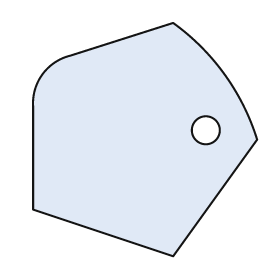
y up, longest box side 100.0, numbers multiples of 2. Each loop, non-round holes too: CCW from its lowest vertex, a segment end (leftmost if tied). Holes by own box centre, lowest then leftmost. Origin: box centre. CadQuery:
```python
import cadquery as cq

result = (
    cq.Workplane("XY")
    .moveTo(12.0, -50.0)
    .lineTo(48.0, 0.0)
    .threePointArc((34.0, 28.0), (12.0, 50.0))
    .lineTo(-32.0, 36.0)
    .threePointArc((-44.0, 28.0), (-48.0, 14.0))
    .lineTo(-48.0, -30.0)
    .close()
    .moveTo(26.0, 4.0)
    .circle(6.0)
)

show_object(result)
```